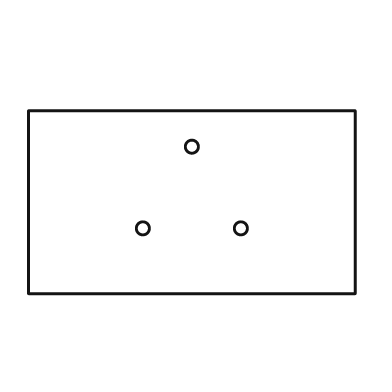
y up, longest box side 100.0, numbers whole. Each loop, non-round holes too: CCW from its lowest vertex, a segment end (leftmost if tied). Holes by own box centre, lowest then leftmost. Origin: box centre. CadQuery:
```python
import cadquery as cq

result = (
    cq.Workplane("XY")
    .moveTo(-50.0, -28.0)
    .lineTo(50.0, -28.0)
    .lineTo(50.0, 28.0)
    .lineTo(-50.0, 28.0)
    .close()
    .moveTo(-15.0, -8.0)
    .circle(2.0)
    .moveTo(15.0, -8.0)
    .circle(2.0)
    .moveTo(0.0, 17.0)
    .circle(2.0)
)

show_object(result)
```